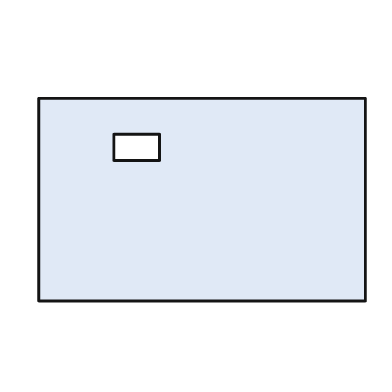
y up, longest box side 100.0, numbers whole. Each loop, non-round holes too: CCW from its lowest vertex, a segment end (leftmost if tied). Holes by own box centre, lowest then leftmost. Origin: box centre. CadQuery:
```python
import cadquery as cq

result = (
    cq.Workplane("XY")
    .moveTo(-50.0, -31.0)
    .lineTo(50.0, -31.0)
    .lineTo(50.0, 31.0)
    .lineTo(-50.0, 31.0)
    .close()
    .moveTo(-27.0, 12.0)
    .lineTo(-13.0, 12.0)
    .lineTo(-13.0, 20.0)
    .lineTo(-27.0, 20.0)
    .close()
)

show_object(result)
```